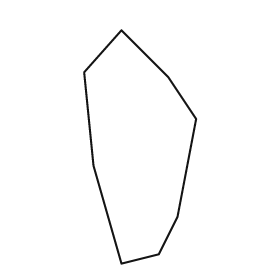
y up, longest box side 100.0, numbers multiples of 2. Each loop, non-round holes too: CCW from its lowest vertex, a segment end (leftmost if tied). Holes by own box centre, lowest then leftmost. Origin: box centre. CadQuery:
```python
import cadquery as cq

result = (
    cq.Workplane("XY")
    .moveTo(-8.0, -50.0)
    .lineTo(8.0, -46.0)
    .lineTo(16.0, -30.0)
    .lineTo(24.0, 12.0)
    .lineTo(12.0, 30.0)
    .lineTo(-8.0, 50.0)
    .lineTo(-24.0, 32.0)
    .lineTo(-20.0, -8.0)
    .close()
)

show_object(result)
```